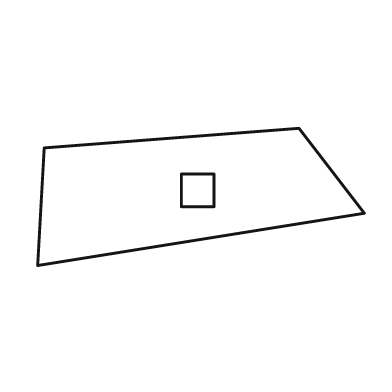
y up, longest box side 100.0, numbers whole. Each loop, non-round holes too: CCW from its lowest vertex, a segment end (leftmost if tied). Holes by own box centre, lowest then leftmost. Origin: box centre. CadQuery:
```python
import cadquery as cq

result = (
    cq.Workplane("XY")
    .moveTo(-50.0, -21.0)
    .lineTo(50.0, -5.0)
    .lineTo(30.0, 21.0)
    .lineTo(-48.0, 15.0)
    .close()
    .moveTo(-6.0, -3.0)
    .lineTo(4.0, -3.0)
    .lineTo(4.0, 7.0)
    .lineTo(-6.0, 7.0)
    .close()
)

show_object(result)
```